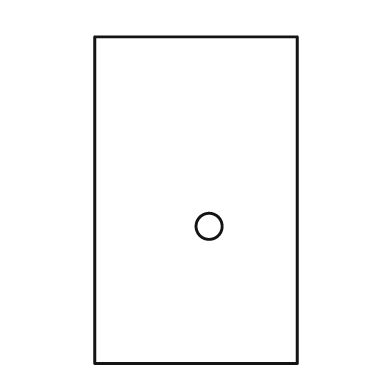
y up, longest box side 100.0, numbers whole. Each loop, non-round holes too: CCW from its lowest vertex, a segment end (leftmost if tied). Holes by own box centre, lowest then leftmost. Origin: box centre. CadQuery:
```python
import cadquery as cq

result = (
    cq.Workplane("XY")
    .moveTo(-31.0, -50.0)
    .lineTo(31.0, -50.0)
    .lineTo(31.0, 50.0)
    .lineTo(-31.0, 50.0)
    .close()
    .moveTo(4.0, -8.0)
    .circle(4.0)
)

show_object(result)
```